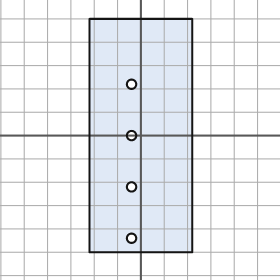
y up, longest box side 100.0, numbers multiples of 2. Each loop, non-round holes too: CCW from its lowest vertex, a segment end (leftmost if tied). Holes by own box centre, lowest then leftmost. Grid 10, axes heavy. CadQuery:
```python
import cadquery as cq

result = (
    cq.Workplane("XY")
    .moveTo(-22.0, -50.0)
    .lineTo(22.0, -50.0)
    .lineTo(22.0, 50.0)
    .lineTo(-22.0, 50.0)
    .close()
    .moveTo(-4.0, -44.0)
    .circle(2.0)
    .moveTo(-4.0, -22.0)
    .circle(2.0)
    .moveTo(-4.0, 0.0)
    .circle(2.0)
    .moveTo(-4.0, 22.0)
    .circle(2.0)
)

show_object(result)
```